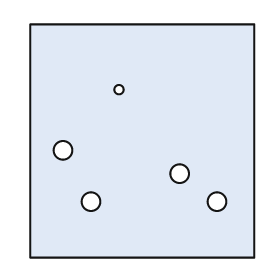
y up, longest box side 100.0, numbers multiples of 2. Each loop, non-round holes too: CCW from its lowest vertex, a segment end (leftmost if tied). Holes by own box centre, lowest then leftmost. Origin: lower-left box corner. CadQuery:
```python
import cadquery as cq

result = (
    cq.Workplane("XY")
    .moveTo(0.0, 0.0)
    .lineTo(96.0, 0.0)
    .lineTo(96.0, 100.0)
    .lineTo(0.0, 100.0)
    .close()
    .moveTo(26.0, 24.0)
    .circle(4.0)
    .moveTo(80.0, 24.0)
    .circle(4.0)
    .moveTo(64.0, 36.0)
    .circle(4.0)
    .moveTo(14.0, 46.0)
    .circle(4.0)
    .moveTo(38.0, 72.0)
    .circle(2.0)
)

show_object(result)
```